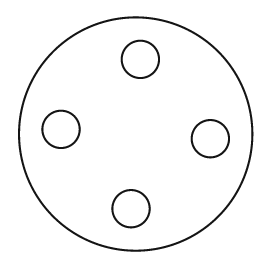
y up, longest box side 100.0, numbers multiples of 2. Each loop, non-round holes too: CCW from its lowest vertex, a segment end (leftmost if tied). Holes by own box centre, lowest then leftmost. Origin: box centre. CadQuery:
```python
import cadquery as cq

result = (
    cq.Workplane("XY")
    .moveTo(0.0, 0.0)
    .circle(50.0)
    .moveTo(-2.0, -32.0)
    .circle(8.0)
    .moveTo(32.0, -2.0)
    .circle(8.0)
    .moveTo(-32.0, 2.0)
    .circle(8.0)
    .moveTo(2.0, 32.0)
    .circle(8.0)
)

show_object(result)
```